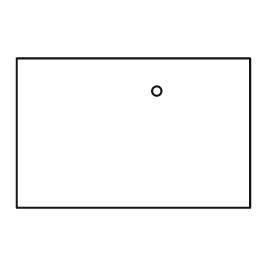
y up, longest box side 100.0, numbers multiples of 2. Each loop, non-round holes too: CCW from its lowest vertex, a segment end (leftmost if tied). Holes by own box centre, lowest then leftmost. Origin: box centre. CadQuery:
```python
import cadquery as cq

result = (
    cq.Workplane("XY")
    .moveTo(-50.0, -32.0)
    .lineTo(50.0, -32.0)
    .lineTo(50.0, 32.0)
    .lineTo(-50.0, 32.0)
    .close()
    .moveTo(10.0, 18.0)
    .circle(2.0)
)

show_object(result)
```